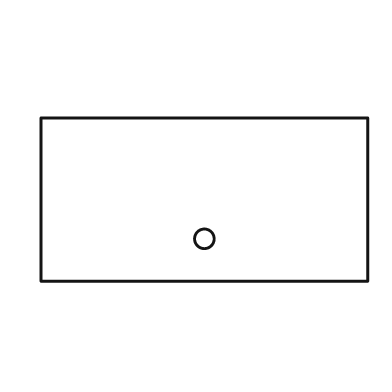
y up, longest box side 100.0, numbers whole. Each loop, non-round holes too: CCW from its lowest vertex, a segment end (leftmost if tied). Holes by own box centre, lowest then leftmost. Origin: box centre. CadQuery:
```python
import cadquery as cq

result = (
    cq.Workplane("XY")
    .moveTo(-50.0, -25.0)
    .lineTo(50.0, -25.0)
    .lineTo(50.0, 25.0)
    .lineTo(-50.0, 25.0)
    .close()
    .moveTo(0.0, -12.0)
    .circle(3.0)
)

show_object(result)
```